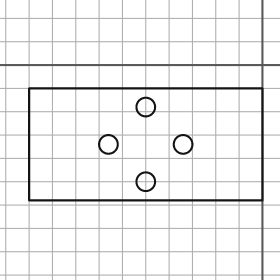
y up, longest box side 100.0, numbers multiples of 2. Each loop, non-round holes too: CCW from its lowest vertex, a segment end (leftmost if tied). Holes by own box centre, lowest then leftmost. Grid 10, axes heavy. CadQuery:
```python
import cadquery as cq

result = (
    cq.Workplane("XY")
    .moveTo(-100.0, -58.0)
    .lineTo(0.0, -58.0)
    .lineTo(0.0, -10.0)
    .lineTo(-100.0, -10.0)
    .close()
    .moveTo(-50.0, -50.0)
    .circle(4.0)
    .moveTo(-66.0, -34.0)
    .circle(4.0)
    .moveTo(-34.0, -34.0)
    .circle(4.0)
    .moveTo(-50.0, -18.0)
    .circle(4.0)
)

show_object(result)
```